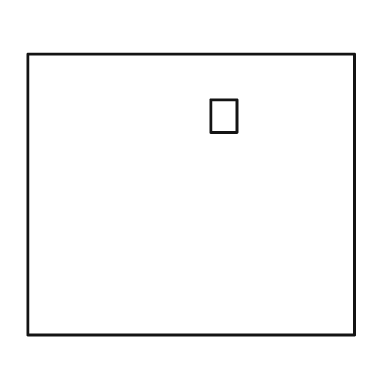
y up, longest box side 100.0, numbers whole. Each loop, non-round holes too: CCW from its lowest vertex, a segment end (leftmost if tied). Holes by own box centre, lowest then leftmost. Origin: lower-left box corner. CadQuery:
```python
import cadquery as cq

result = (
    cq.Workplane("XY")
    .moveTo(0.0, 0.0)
    .lineTo(100.0, 0.0)
    .lineTo(100.0, 86.0)
    .lineTo(0.0, 86.0)
    .close()
    .moveTo(56.0, 62.0)
    .lineTo(64.0, 62.0)
    .lineTo(64.0, 72.0)
    .lineTo(56.0, 72.0)
    .close()
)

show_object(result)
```